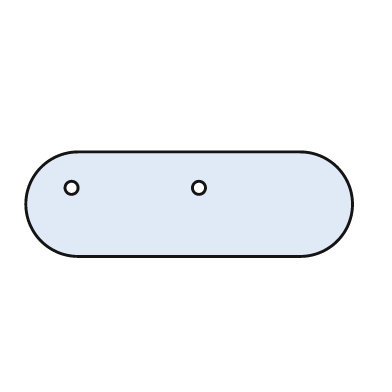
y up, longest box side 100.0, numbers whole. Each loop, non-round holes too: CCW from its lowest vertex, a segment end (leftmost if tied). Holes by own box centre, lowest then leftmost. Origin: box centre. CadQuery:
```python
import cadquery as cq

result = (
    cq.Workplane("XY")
    .moveTo(-34.0, -16.0)
    .lineTo(34.0, -16.0)
    .threePointArc((50.0, 0.0), (34.0, 16.0))
    .lineTo(-34.0, 16.0)
    .threePointArc((-50.0, 0.0), (-34.0, -16.0))
    .close()
    .moveTo(-36.0, 5.0)
    .circle(2.0)
    .moveTo(3.0, 5.0)
    .circle(2.0)
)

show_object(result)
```